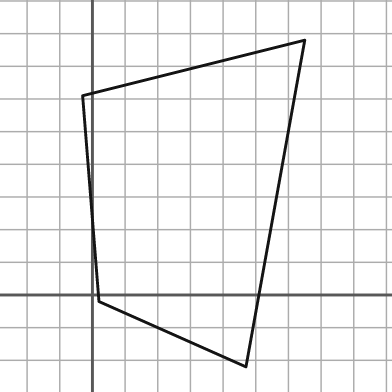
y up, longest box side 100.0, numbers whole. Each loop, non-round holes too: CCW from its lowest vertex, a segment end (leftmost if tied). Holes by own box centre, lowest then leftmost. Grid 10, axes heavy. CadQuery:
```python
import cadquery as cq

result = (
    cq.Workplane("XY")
    .moveTo(47.0, -22.0)
    .lineTo(65.0, 78.0)
    .lineTo(-3.0, 61.0)
    .lineTo(2.0, -2.0)
    .close()
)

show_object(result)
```